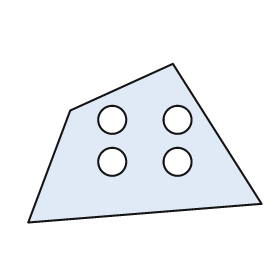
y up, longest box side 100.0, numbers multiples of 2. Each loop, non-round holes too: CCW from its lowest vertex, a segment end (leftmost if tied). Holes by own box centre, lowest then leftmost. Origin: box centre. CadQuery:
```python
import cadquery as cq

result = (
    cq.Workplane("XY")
    .moveTo(-50.0, -34.0)
    .lineTo(50.0, -26.0)
    .lineTo(12.0, 34.0)
    .lineTo(-32.0, 14.0)
    .close()
    .moveTo(-14.0, -8.0)
    .circle(6.0)
    .moveTo(14.0, -8.0)
    .circle(6.0)
    .moveTo(-14.0, 10.0)
    .circle(6.0)
    .moveTo(14.0, 10.0)
    .circle(6.0)
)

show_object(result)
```